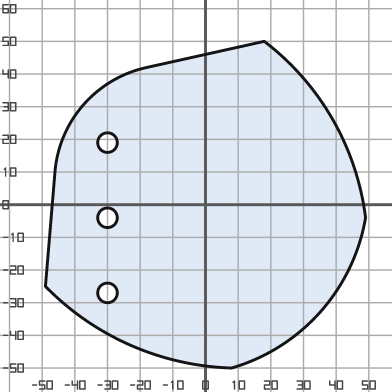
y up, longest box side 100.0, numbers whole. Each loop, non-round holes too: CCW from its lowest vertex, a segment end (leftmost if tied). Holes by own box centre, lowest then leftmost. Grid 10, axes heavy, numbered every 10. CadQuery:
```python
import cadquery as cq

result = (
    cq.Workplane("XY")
    .moveTo(8.0, -50.0)
    .threePointArc((35.0, -33.0), (49.0, -4.0))
    .threePointArc((39.0, 26.0), (18.0, 50.0))
    .lineTo(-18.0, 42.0)
    .threePointArc((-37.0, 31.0), (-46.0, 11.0))
    .lineTo(-49.0, -25.0)
    .threePointArc((-23.0, -43.0), (8.0, -50.0))
    .close()
    .moveTo(-30.0, -27.0)
    .circle(3.0)
    .moveTo(-30.0, -4.0)
    .circle(3.0)
    .moveTo(-30.0, 19.0)
    .circle(3.0)
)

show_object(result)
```